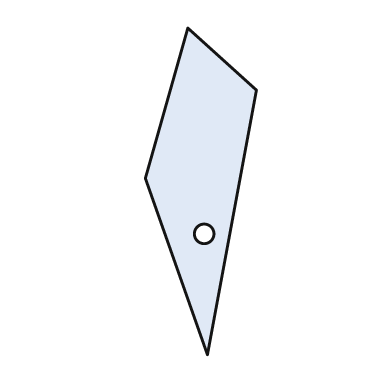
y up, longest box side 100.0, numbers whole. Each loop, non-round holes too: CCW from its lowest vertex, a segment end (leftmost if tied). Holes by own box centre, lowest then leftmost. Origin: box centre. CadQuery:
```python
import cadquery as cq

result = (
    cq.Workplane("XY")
    .moveTo(2.0, -50.0)
    .lineTo(17.0, 31.0)
    .lineTo(-4.0, 50.0)
    .lineTo(-17.0, 4.0)
    .close()
    .moveTo(1.0, -13.0)
    .circle(3.0)
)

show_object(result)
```